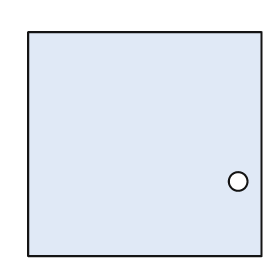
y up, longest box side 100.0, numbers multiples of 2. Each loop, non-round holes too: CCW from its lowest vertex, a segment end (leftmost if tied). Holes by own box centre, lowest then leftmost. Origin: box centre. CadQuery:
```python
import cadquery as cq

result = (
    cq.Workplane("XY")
    .moveTo(-50.0, -48.0)
    .lineTo(50.0, -48.0)
    .lineTo(50.0, 48.0)
    .lineTo(-50.0, 48.0)
    .close()
    .moveTo(40.0, -16.0)
    .circle(4.0)
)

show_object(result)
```